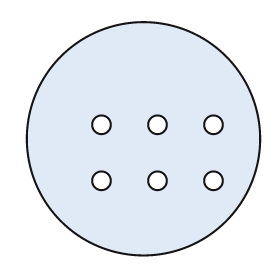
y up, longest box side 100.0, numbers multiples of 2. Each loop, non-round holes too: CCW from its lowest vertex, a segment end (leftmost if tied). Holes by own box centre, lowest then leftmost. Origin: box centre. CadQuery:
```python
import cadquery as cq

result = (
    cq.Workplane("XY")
    .moveTo(0.0, 0.0)
    .circle(50.0)
    .moveTo(-18.0, -18.0)
    .circle(4.0)
    .moveTo(6.0, -18.0)
    .circle(4.0)
    .moveTo(30.0, -18.0)
    .circle(4.0)
    .moveTo(-18.0, 6.0)
    .circle(4.0)
    .moveTo(6.0, 6.0)
    .circle(4.0)
    .moveTo(30.0, 6.0)
    .circle(4.0)
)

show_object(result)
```